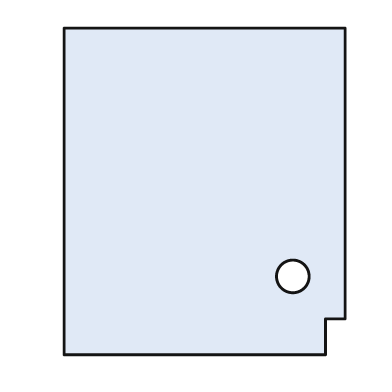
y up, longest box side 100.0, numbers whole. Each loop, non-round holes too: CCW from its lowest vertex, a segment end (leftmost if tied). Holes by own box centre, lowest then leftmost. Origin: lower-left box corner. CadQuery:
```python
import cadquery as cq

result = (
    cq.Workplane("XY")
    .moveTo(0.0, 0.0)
    .lineTo(80.0, 0.0)
    .lineTo(80.0, 11.0)
    .lineTo(86.0, 11.0)
    .lineTo(86.0, 100.0)
    .lineTo(0.0, 100.0)
    .close()
    .moveTo(70.0, 24.0)
    .circle(5.0)
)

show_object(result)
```